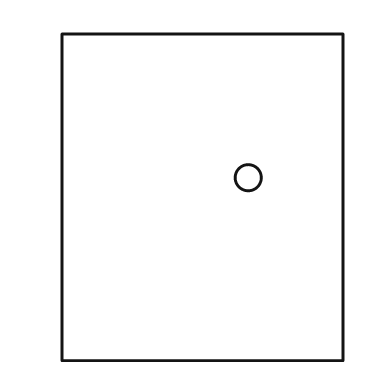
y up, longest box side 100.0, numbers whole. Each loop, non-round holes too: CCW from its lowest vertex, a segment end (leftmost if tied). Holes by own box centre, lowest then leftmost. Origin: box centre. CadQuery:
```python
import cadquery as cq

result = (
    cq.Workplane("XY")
    .moveTo(-43.0, -50.0)
    .lineTo(43.0, -50.0)
    .lineTo(43.0, 50.0)
    .lineTo(-43.0, 50.0)
    .close()
    .moveTo(14.0, 6.0)
    .circle(4.0)
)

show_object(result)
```